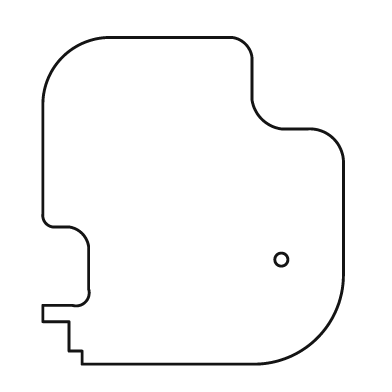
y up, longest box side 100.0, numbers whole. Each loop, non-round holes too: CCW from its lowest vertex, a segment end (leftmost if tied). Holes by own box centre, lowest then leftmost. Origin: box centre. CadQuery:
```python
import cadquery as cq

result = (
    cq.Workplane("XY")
    .moveTo(-34.0, -50.0)
    .lineTo(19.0, -50.0)
    .threePointArc((38.0, -42.0), (46.0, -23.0))
    .lineTo(46.0, 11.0)
    .threePointArc((43.0, 19.0), (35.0, 22.0))
    .lineTo(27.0, 22.0)
    .threePointArc((21.0, 25.0), (18.0, 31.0))
    .lineTo(18.0, 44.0)
    .threePointArc((16.0, 48.0), (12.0, 50.0))
    .lineTo(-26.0, 50.0)
    .threePointArc((-40.0, 44.0), (-46.0, 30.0))
    .lineTo(-46.0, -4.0)
    .threePointArc((-45.0, -7.0), (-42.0, -8.0))
    .lineTo(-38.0, -8.0)
    .threePointArc((-34.0, -10.0), (-32.0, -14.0))
    .lineTo(-32.0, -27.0)
    .threePointArc((-33.0, -31.0), (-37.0, -32.0))
    .lineTo(-46.0, -32.0)
    .lineTo(-46.0, -37.0)
    .lineTo(-38.0, -37.0)
    .lineTo(-38.0, -46.0)
    .lineTo(-34.0, -46.0)
    .close()
    .moveTo(27.0, -18.0)
    .circle(2.0)
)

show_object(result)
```